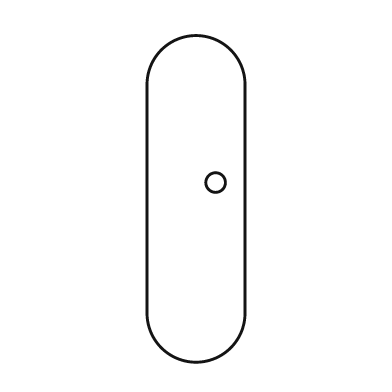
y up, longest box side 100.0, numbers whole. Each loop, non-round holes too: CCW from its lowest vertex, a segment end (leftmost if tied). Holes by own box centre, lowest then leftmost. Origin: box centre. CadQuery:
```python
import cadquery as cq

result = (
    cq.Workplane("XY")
    .moveTo(-15.0, -35.0)
    .threePointArc((0.0, -50.0), (15.0, -35.0))
    .lineTo(15.0, 35.0)
    .threePointArc((0.0, 50.0), (-15.0, 35.0))
    .close()
    .moveTo(6.0, 5.0)
    .circle(3.0)
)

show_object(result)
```